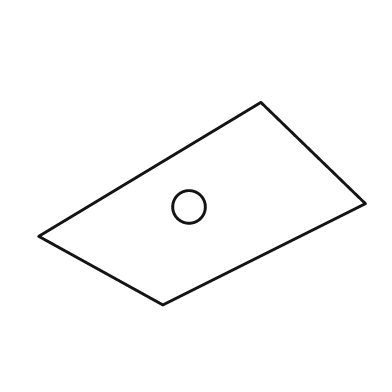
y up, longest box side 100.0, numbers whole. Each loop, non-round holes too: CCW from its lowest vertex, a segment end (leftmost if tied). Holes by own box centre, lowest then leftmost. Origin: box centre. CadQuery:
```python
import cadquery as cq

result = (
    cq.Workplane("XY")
    .moveTo(-12.0, -31.0)
    .lineTo(50.0, 0.0)
    .lineTo(18.0, 31.0)
    .lineTo(-50.0, -10.0)
    .close()
    .moveTo(-4.0, -1.0)
    .circle(5.0)
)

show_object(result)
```